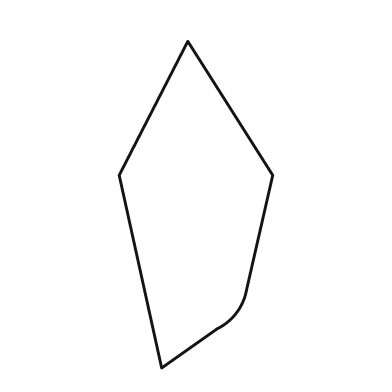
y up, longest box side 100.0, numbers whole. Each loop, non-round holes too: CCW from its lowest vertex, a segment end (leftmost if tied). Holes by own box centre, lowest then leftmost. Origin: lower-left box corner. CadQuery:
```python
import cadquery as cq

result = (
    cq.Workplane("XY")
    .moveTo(13.0, 0.0)
    .lineTo(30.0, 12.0)
    .threePointArc((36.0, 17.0), (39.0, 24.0))
    .lineTo(47.0, 59.0)
    .lineTo(21.0, 100.0)
    .lineTo(0.0, 59.0)
    .close()
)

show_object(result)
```